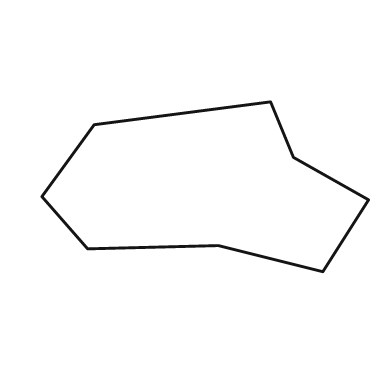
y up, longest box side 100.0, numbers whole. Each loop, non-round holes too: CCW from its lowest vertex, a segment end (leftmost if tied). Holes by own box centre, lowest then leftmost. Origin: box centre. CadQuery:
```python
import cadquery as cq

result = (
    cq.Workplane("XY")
    .moveTo(36.0, -26.0)
    .lineTo(50.0, -4.0)
    .lineTo(27.0, 9.0)
    .lineTo(20.0, 26.0)
    .lineTo(-34.0, 19.0)
    .lineTo(-50.0, -3.0)
    .lineTo(-36.0, -19.0)
    .lineTo(4.0, -18.0)
    .close()
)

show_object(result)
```